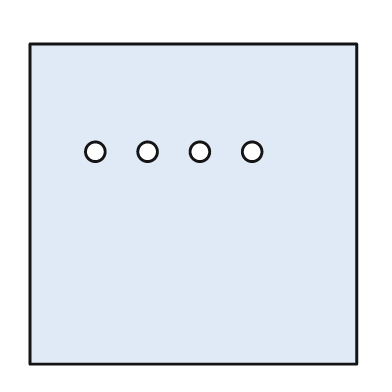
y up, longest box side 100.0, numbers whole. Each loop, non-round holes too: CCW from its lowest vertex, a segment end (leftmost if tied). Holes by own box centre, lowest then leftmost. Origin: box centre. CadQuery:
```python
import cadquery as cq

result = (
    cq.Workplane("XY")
    .moveTo(-50.0, -49.0)
    .lineTo(50.0, -49.0)
    .lineTo(50.0, 49.0)
    .lineTo(-50.0, 49.0)
    .close()
    .moveTo(-30.0, 16.0)
    .circle(3.0)
    .moveTo(-14.0, 16.0)
    .circle(3.0)
    .moveTo(2.0, 16.0)
    .circle(3.0)
    .moveTo(18.0, 16.0)
    .circle(3.0)
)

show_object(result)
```